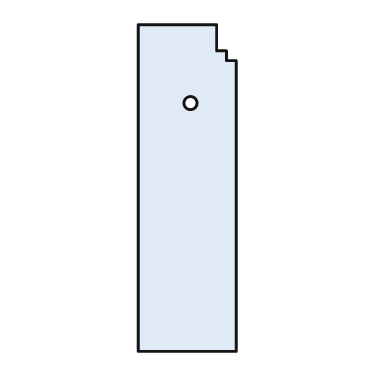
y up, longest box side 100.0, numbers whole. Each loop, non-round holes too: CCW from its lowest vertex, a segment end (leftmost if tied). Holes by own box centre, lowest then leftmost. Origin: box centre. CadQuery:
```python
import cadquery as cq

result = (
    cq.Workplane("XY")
    .moveTo(-15.0, -50.0)
    .lineTo(15.0, -50.0)
    .lineTo(15.0, 39.0)
    .lineTo(12.0, 39.0)
    .lineTo(12.0, 42.0)
    .lineTo(9.0, 42.0)
    .lineTo(9.0, 50.0)
    .lineTo(-15.0, 50.0)
    .close()
    .moveTo(1.0, 26.0)
    .circle(2.0)
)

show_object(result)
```